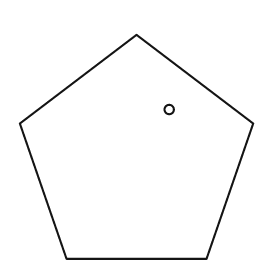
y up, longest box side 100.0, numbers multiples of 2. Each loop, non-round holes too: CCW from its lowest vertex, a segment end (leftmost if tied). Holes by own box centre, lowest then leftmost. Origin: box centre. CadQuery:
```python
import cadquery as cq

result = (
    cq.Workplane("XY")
    .moveTo(-30.0, -48.0)
    .lineTo(30.0, -48.0)
    .lineTo(50.0, 10.0)
    .lineTo(0.0, 48.0)
    .lineTo(-50.0, 10.0)
    .close()
    .moveTo(14.0, 16.0)
    .circle(2.0)
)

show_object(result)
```